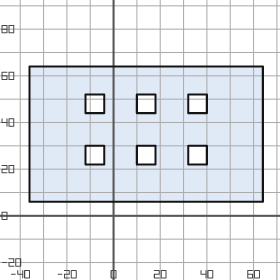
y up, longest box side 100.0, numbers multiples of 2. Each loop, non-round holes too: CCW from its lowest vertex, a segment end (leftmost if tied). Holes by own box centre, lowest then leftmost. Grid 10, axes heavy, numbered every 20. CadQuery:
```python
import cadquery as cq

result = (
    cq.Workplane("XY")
    .moveTo(-36.0, 6.0)
    .lineTo(64.0, 6.0)
    .lineTo(64.0, 64.0)
    .lineTo(-36.0, 64.0)
    .close()
    .moveTo(-12.0, 22.0)
    .lineTo(-4.0, 22.0)
    .lineTo(-4.0, 30.0)
    .lineTo(-12.0, 30.0)
    .close()
    .moveTo(10.0, 22.0)
    .lineTo(18.0, 22.0)
    .lineTo(18.0, 30.0)
    .lineTo(10.0, 30.0)
    .close()
    .moveTo(32.0, 22.0)
    .lineTo(40.0, 22.0)
    .lineTo(40.0, 30.0)
    .lineTo(32.0, 30.0)
    .close()
    .moveTo(-12.0, 44.0)
    .lineTo(-4.0, 44.0)
    .lineTo(-4.0, 52.0)
    .lineTo(-12.0, 52.0)
    .close()
    .moveTo(10.0, 44.0)
    .lineTo(18.0, 44.0)
    .lineTo(18.0, 52.0)
    .lineTo(10.0, 52.0)
    .close()
    .moveTo(32.0, 44.0)
    .lineTo(40.0, 44.0)
    .lineTo(40.0, 52.0)
    .lineTo(32.0, 52.0)
    .close()
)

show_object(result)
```